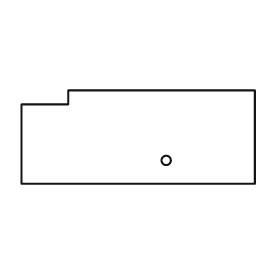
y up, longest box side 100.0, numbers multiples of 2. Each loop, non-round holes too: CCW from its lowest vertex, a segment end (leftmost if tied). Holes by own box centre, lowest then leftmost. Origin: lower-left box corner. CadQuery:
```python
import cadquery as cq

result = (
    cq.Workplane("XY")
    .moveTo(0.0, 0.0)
    .lineTo(100.0, 0.0)
    .lineTo(100.0, 40.0)
    .lineTo(20.0, 40.0)
    .lineTo(20.0, 34.0)
    .lineTo(0.0, 34.0)
    .close()
    .moveTo(62.0, 10.0)
    .circle(2.0)
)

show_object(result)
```